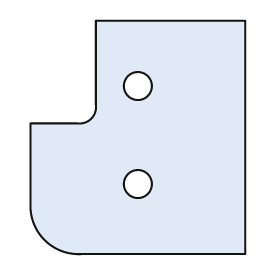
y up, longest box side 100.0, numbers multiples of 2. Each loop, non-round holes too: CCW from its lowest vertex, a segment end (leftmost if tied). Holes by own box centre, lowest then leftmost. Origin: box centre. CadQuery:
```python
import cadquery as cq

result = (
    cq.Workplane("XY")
    .moveTo(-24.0, -50.0)
    .lineTo(46.0, -50.0)
    .lineTo(46.0, 50.0)
    .lineTo(-18.0, 50.0)
    .lineTo(-18.0, 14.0)
    .threePointArc((-20.0, 8.0), (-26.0, 6.0))
    .lineTo(-46.0, 6.0)
    .lineTo(-46.0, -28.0)
    .threePointArc((-40.0, -44.0), (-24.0, -50.0))
    .close()
    .moveTo(0.0, -20.0)
    .circle(6.0)
    .moveTo(0.0, 22.0)
    .circle(6.0)
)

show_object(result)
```